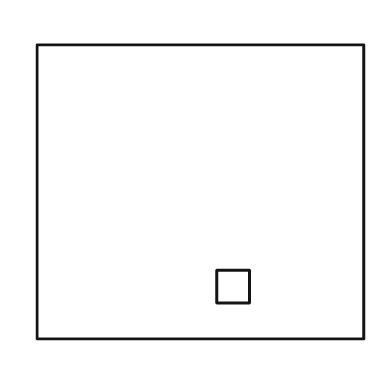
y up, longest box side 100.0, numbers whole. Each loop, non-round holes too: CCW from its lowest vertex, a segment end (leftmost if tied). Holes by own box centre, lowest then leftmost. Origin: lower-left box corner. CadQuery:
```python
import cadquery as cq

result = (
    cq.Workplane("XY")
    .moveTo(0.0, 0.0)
    .lineTo(100.0, 0.0)
    .lineTo(100.0, 90.0)
    .lineTo(0.0, 90.0)
    .close()
    .moveTo(55.0, 11.0)
    .lineTo(65.0, 11.0)
    .lineTo(65.0, 21.0)
    .lineTo(55.0, 21.0)
    .close()
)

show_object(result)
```